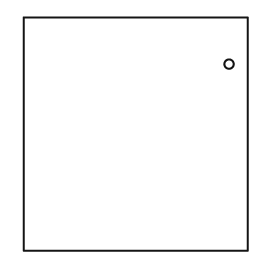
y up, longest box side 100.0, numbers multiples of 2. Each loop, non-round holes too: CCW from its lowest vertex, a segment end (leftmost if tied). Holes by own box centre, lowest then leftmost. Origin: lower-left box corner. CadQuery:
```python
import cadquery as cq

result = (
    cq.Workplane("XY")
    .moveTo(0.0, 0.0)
    .lineTo(96.0, 0.0)
    .lineTo(96.0, 100.0)
    .lineTo(0.0, 100.0)
    .close()
    .moveTo(88.0, 80.0)
    .circle(2.0)
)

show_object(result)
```